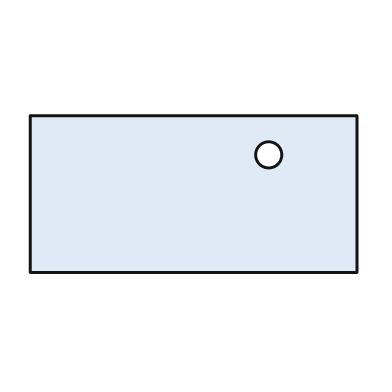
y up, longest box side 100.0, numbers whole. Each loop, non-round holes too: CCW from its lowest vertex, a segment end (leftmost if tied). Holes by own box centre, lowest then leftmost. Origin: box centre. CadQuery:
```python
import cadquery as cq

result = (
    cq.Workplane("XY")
    .moveTo(-50.0, -24.0)
    .lineTo(50.0, -24.0)
    .lineTo(50.0, 24.0)
    .lineTo(-50.0, 24.0)
    .close()
    .moveTo(23.0, 12.0)
    .circle(4.0)
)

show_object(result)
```